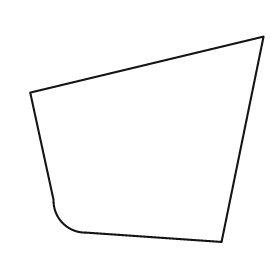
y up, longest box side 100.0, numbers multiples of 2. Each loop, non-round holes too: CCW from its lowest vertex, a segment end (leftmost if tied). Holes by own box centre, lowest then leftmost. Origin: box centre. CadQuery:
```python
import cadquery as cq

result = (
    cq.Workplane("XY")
    .moveTo(32.0, -44.0)
    .lineTo(50.0, 44.0)
    .lineTo(-50.0, 20.0)
    .lineTo(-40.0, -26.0)
    .threePointArc((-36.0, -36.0), (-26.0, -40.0))
    .close()
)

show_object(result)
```